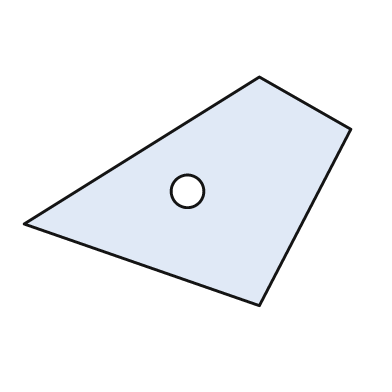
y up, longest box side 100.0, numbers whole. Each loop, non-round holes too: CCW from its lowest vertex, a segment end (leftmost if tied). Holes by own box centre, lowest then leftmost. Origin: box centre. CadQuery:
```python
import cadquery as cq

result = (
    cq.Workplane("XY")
    .moveTo(22.0, -35.0)
    .lineTo(50.0, 19.0)
    .lineTo(22.0, 35.0)
    .lineTo(-50.0, -10.0)
    .close()
    .moveTo(0.0, 0.0)
    .circle(5.0)
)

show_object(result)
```